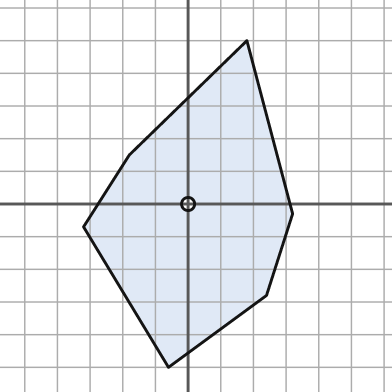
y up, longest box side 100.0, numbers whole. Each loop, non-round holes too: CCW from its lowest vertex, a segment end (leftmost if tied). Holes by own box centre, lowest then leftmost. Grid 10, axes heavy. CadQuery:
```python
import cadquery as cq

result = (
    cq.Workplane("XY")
    .moveTo(-6.0, -50.0)
    .lineTo(24.0, -28.0)
    .lineTo(32.0, -3.0)
    .lineTo(18.0, 50.0)
    .lineTo(-18.0, 15.0)
    .lineTo(-32.0, -7.0)
    .close()
    .moveTo(0.0, 0.0)
    .circle(2.0)
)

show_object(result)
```